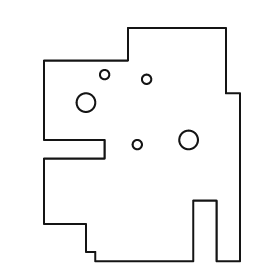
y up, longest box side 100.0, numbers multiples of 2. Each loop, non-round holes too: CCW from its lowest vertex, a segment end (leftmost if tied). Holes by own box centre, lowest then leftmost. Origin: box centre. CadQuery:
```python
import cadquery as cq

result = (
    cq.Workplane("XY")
    .moveTo(-20.0, -50.0)
    .lineTo(22.0, -50.0)
    .lineTo(22.0, -24.0)
    .lineTo(32.0, -24.0)
    .lineTo(32.0, -50.0)
    .lineTo(42.0, -50.0)
    .lineTo(42.0, 22.0)
    .lineTo(36.0, 22.0)
    .lineTo(36.0, 50.0)
    .lineTo(-6.0, 50.0)
    .lineTo(-6.0, 36.0)
    .lineTo(-42.0, 36.0)
    .lineTo(-42.0, 2.0)
    .lineTo(-16.0, 2.0)
    .lineTo(-16.0, -6.0)
    .lineTo(-42.0, -6.0)
    .lineTo(-42.0, -34.0)
    .lineTo(-24.0, -34.0)
    .lineTo(-24.0, -46.0)
    .lineTo(-20.0, -46.0)
    .close()
    .moveTo(-2.0, 0.0)
    .circle(2.0)
    .moveTo(20.0, 2.0)
    .circle(4.0)
    .moveTo(-24.0, 18.0)
    .circle(4.0)
    .moveTo(2.0, 28.0)
    .circle(2.0)
    .moveTo(-16.0, 30.0)
    .circle(2.0)
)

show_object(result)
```